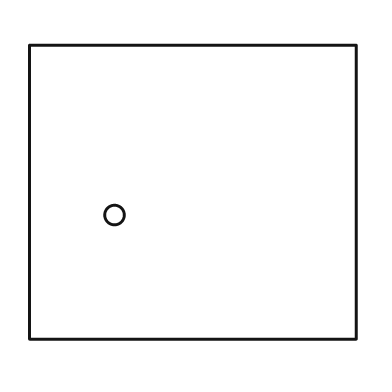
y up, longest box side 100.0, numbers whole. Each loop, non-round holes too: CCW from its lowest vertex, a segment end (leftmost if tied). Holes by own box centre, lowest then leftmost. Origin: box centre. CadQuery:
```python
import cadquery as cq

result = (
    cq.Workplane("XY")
    .moveTo(-50.0, -45.0)
    .lineTo(50.0, -45.0)
    .lineTo(50.0, 45.0)
    .lineTo(-50.0, 45.0)
    .close()
    .moveTo(-24.0, -7.0)
    .circle(3.0)
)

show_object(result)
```